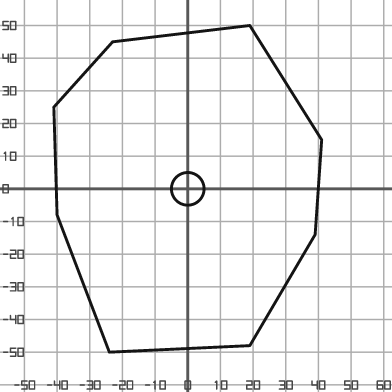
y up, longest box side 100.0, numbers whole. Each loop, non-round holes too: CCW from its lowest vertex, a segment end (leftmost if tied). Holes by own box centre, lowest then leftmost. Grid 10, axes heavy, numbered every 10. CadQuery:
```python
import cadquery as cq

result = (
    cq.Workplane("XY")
    .moveTo(-24.0, -50.0)
    .lineTo(19.0, -48.0)
    .lineTo(39.0, -14.0)
    .lineTo(41.0, 15.0)
    .lineTo(19.0, 50.0)
    .lineTo(-23.0, 45.0)
    .lineTo(-41.0, 25.0)
    .lineTo(-40.0, -8.0)
    .close()
    .moveTo(0.0, 0.0)
    .circle(5.0)
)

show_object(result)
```